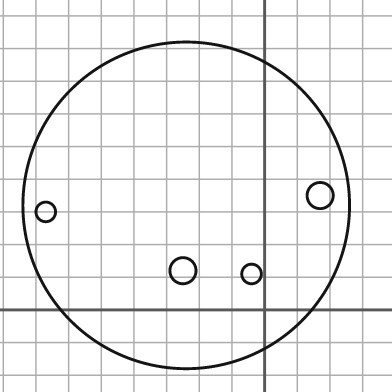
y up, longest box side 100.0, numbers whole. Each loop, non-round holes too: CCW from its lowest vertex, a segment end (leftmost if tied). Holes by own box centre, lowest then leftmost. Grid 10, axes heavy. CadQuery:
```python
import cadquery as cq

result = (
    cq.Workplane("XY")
    .moveTo(-24.0, 32.0)
    .circle(50.0)
    .moveTo(-4.0, 11.0)
    .circle(3.0)
    .moveTo(-25.0, 12.0)
    .circle(4.0)
    .moveTo(-67.0, 30.0)
    .circle(3.0)
    .moveTo(17.0, 35.0)
    .circle(4.0)
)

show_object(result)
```